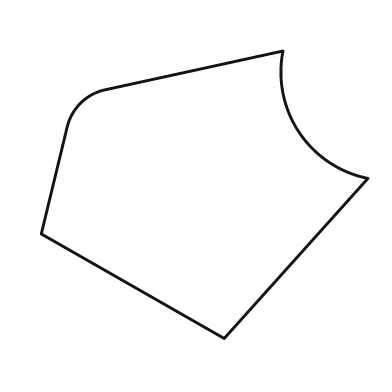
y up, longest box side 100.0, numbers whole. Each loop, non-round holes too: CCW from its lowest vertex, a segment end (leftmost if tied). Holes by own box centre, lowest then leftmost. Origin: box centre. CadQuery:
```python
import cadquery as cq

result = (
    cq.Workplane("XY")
    .moveTo(6.0, -44.0)
    .lineTo(50.0, 5.0)
    .threePointArc((29.0, 19.0), (24.0, 44.0))
    .lineTo(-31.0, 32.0)
    .threePointArc((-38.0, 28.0), (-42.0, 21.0))
    .lineTo(-50.0, -12.0)
    .close()
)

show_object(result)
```